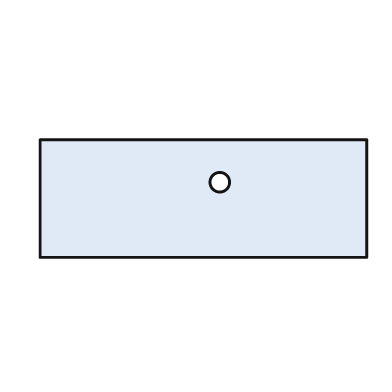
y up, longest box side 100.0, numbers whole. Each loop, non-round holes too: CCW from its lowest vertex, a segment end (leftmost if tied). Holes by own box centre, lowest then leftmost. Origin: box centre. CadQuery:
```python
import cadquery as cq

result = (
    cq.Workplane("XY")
    .moveTo(-50.0, -18.0)
    .lineTo(50.0, -18.0)
    .lineTo(50.0, 18.0)
    .lineTo(-50.0, 18.0)
    .close()
    .moveTo(5.0, 5.0)
    .circle(3.0)
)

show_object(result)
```